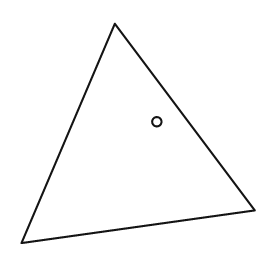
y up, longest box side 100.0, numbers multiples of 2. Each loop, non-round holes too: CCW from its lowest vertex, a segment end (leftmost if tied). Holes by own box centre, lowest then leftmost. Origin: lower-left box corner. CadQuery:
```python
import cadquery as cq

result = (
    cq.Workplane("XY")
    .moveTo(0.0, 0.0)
    .lineTo(100.0, 14.0)
    .lineTo(40.0, 94.0)
    .close()
    .moveTo(58.0, 52.0)
    .circle(2.0)
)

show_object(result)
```